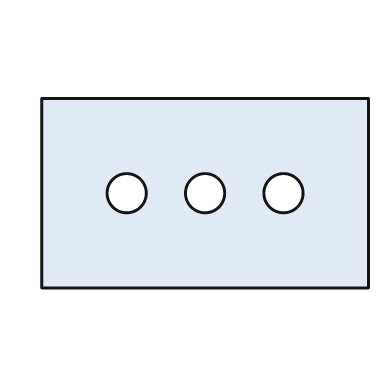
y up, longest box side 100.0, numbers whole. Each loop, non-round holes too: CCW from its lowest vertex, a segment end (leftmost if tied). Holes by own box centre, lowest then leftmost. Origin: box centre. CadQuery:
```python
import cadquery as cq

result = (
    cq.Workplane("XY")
    .moveTo(-50.0, -29.0)
    .lineTo(50.0, -29.0)
    .lineTo(50.0, 29.0)
    .lineTo(-50.0, 29.0)
    .close()
    .moveTo(-24.0, 0.0)
    .circle(6.0)
    .moveTo(0.0, 0.0)
    .circle(6.0)
    .moveTo(24.0, 0.0)
    .circle(6.0)
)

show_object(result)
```